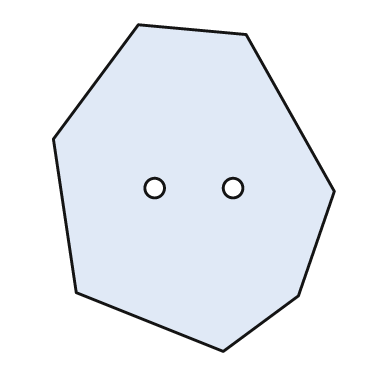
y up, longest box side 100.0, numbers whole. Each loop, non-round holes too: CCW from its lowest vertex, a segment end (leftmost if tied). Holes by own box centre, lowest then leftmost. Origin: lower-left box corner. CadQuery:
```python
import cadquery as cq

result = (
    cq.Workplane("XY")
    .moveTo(52.0, 0.0)
    .lineTo(75.0, 17.0)
    .lineTo(86.0, 49.0)
    .lineTo(59.0, 97.0)
    .lineTo(26.0, 100.0)
    .lineTo(0.0, 65.0)
    .lineTo(7.0, 18.0)
    .close()
    .moveTo(31.0, 50.0)
    .circle(3.0)
    .moveTo(55.0, 50.0)
    .circle(3.0)
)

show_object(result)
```